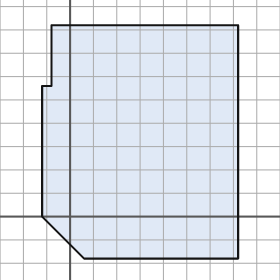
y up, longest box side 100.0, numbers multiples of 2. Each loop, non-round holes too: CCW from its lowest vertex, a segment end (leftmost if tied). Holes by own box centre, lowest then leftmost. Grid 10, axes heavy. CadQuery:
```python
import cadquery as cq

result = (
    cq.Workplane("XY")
    .moveTo(6.0, -18.0)
    .lineTo(72.0, -18.0)
    .lineTo(72.0, 82.0)
    .lineTo(-8.0, 82.0)
    .lineTo(-8.0, 56.0)
    .lineTo(-12.0, 56.0)
    .lineTo(-12.0, 0.0)
    .close()
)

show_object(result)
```